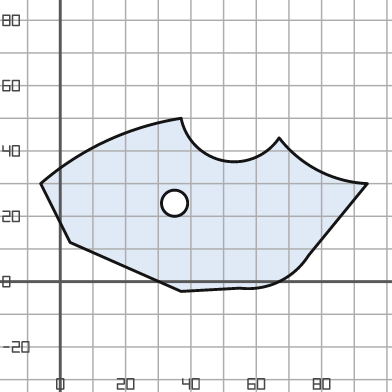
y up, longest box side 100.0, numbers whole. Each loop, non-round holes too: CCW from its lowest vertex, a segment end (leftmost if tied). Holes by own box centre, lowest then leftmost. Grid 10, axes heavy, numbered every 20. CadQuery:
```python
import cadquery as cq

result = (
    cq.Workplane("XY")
    .moveTo(37.0, -3.0)
    .lineTo(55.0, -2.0)
    .threePointArc((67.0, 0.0), (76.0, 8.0))
    .lineTo(94.0, 30.0)
    .threePointArc((79.0, 34.0), (67.0, 44.0))
    .threePointArc((50.0, 37.0), (37.0, 50.0))
    .threePointArc((14.0, 43.0), (-6.0, 30.0))
    .lineTo(3.0, 12.0)
    .close()
    .moveTo(35.0, 24.0)
    .circle(4.0)
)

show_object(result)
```